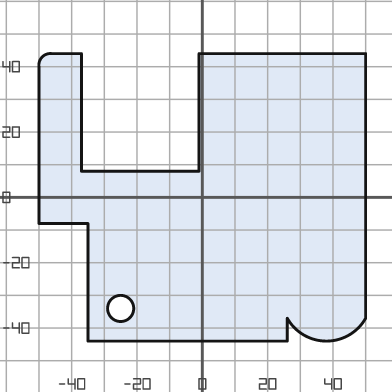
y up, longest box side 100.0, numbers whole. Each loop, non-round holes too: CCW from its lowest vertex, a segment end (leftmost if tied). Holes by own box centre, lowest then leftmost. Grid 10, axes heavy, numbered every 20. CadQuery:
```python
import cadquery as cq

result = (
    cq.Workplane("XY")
    .moveTo(-35.0, -44.0)
    .lineTo(26.0, -44.0)
    .lineTo(26.0, -37.0)
    .threePointArc((38.0, -44.0), (50.0, -37.0))
    .lineTo(50.0, 44.0)
    .lineTo(-1.0, 44.0)
    .lineTo(-1.0, 8.0)
    .lineTo(-37.0, 8.0)
    .lineTo(-37.0, 44.0)
    .lineTo(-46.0, 44.0)
    .threePointArc((-49.0, 43.0), (-50.0, 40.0))
    .lineTo(-50.0, -8.0)
    .lineTo(-35.0, -8.0)
    .close()
    .moveTo(-25.0, -34.0)
    .circle(4.0)
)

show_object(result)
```